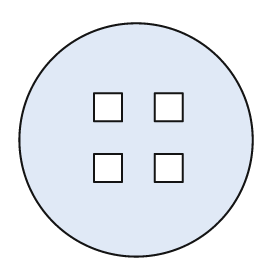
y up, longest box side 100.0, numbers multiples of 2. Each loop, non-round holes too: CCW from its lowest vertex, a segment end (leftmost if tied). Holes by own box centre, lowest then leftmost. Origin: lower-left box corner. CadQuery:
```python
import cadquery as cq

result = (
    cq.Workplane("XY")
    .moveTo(50.0, 50.0)
    .circle(50.0)
    .moveTo(32.0, 32.0)
    .lineTo(44.0, 32.0)
    .lineTo(44.0, 44.0)
    .lineTo(32.0, 44.0)
    .close()
    .moveTo(58.0, 32.0)
    .lineTo(70.0, 32.0)
    .lineTo(70.0, 44.0)
    .lineTo(58.0, 44.0)
    .close()
    .moveTo(32.0, 58.0)
    .lineTo(44.0, 58.0)
    .lineTo(44.0, 70.0)
    .lineTo(32.0, 70.0)
    .close()
    .moveTo(58.0, 58.0)
    .lineTo(70.0, 58.0)
    .lineTo(70.0, 70.0)
    .lineTo(58.0, 70.0)
    .close()
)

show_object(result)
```